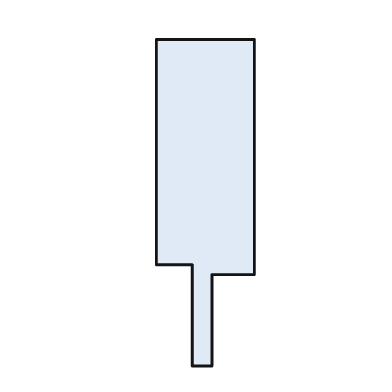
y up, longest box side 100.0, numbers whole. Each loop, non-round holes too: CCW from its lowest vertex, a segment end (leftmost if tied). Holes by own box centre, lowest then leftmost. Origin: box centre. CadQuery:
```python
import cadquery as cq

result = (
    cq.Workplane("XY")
    .moveTo(-4.0, -50.0)
    .lineTo(2.0, -50.0)
    .lineTo(2.0, -22.0)
    .lineTo(15.0, -22.0)
    .lineTo(15.0, 50.0)
    .lineTo(-15.0, 50.0)
    .lineTo(-15.0, -19.0)
    .lineTo(-4.0, -19.0)
    .close()
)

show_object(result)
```